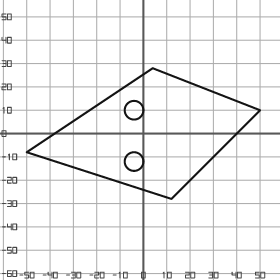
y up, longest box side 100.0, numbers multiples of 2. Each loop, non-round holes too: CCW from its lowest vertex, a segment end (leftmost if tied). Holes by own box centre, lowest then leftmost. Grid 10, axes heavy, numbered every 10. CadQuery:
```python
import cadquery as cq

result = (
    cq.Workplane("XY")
    .moveTo(12.0, -28.0)
    .lineTo(50.0, 10.0)
    .lineTo(4.0, 28.0)
    .lineTo(-50.0, -8.0)
    .close()
    .moveTo(-4.0, -12.0)
    .circle(4.0)
    .moveTo(-4.0, 10.0)
    .circle(4.0)
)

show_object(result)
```